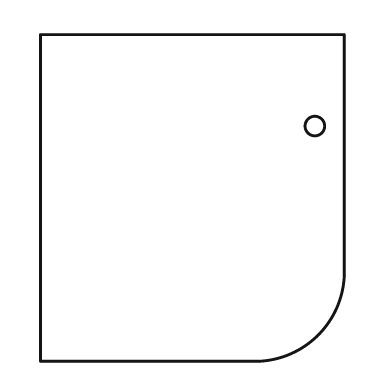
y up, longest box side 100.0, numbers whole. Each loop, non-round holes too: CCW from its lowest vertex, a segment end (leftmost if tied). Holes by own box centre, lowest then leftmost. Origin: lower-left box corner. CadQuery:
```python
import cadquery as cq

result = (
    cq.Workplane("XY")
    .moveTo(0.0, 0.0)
    .lineTo(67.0, 0.0)
    .threePointArc((85.0, 8.0), (93.0, 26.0))
    .lineTo(93.0, 100.0)
    .lineTo(0.0, 100.0)
    .close()
    .moveTo(84.0, 72.0)
    .circle(3.0)
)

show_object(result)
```